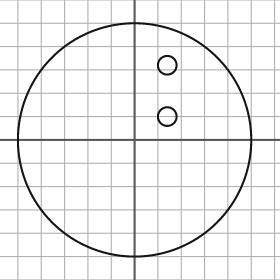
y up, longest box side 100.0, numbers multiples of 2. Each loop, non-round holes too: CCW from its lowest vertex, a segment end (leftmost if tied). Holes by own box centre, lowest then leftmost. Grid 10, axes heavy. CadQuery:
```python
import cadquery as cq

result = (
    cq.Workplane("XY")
    .moveTo(0.0, 0.0)
    .circle(50.0)
    .moveTo(14.0, 10.0)
    .circle(4.0)
    .moveTo(14.0, 32.0)
    .circle(4.0)
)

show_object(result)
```